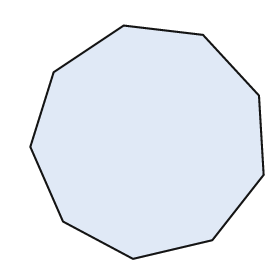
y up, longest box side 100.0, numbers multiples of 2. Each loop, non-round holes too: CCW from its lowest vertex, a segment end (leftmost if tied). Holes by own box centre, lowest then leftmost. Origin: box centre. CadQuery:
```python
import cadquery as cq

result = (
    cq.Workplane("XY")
    .moveTo(-6.0, -50.0)
    .lineTo(28.0, -42.0)
    .lineTo(50.0, -14.0)
    .lineTo(48.0, 20.0)
    .lineTo(24.0, 46.0)
    .lineTo(-10.0, 50.0)
    .lineTo(-40.0, 30.0)
    .lineTo(-50.0, -2.0)
    .lineTo(-36.0, -34.0)
    .close()
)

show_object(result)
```